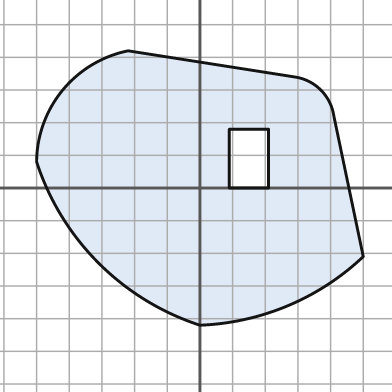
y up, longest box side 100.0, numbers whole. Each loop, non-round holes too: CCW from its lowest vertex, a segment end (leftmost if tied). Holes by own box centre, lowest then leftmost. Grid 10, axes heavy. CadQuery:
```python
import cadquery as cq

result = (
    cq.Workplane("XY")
    .moveTo(0.0, -42.0)
    .threePointArc((27.0, -36.0), (50.0, -21.0))
    .lineTo(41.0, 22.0)
    .threePointArc((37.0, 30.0), (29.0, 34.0))
    .lineTo(-22.0, 42.0)
    .threePointArc((-42.0, 30.0), (-50.0, 8.0))
    .threePointArc((-31.0, -23.0), (0.0, -42.0))
    .close()
    .moveTo(9.0, 0.0)
    .lineTo(21.0, 0.0)
    .lineTo(21.0, 18.0)
    .lineTo(9.0, 18.0)
    .close()
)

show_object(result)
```